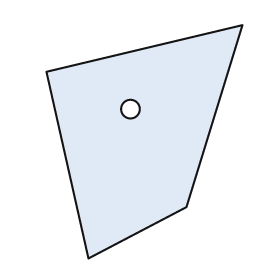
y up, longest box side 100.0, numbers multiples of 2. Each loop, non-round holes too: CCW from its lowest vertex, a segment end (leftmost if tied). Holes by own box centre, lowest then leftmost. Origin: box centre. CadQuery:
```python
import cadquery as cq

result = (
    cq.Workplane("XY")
    .moveTo(-24.0, -50.0)
    .lineTo(18.0, -28.0)
    .lineTo(42.0, 50.0)
    .lineTo(-42.0, 30.0)
    .close()
    .moveTo(-6.0, 14.0)
    .circle(4.0)
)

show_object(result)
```